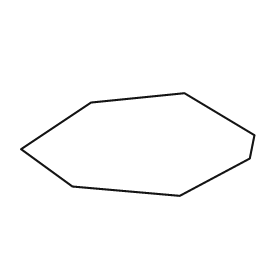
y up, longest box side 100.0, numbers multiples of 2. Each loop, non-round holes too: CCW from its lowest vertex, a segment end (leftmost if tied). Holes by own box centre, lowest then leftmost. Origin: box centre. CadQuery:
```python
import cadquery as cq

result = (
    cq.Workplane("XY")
    .moveTo(18.0, -22.0)
    .lineTo(48.0, -6.0)
    .lineTo(50.0, 4.0)
    .lineTo(20.0, 22.0)
    .lineTo(-20.0, 18.0)
    .lineTo(-50.0, -2.0)
    .lineTo(-28.0, -18.0)
    .close()
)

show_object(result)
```